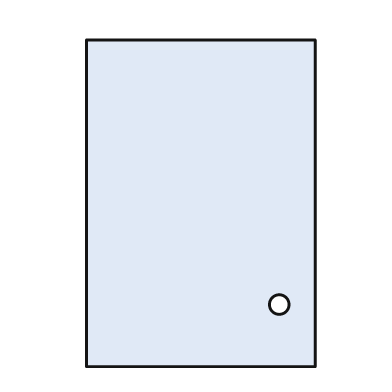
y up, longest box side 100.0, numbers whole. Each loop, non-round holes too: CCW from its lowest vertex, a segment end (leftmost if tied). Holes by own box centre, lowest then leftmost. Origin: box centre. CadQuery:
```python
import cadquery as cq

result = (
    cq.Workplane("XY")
    .moveTo(-35.0, -50.0)
    .lineTo(35.0, -50.0)
    .lineTo(35.0, 50.0)
    .lineTo(-35.0, 50.0)
    .close()
    .moveTo(24.0, -31.0)
    .circle(3.0)
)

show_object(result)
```